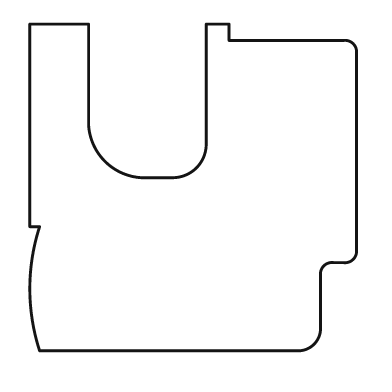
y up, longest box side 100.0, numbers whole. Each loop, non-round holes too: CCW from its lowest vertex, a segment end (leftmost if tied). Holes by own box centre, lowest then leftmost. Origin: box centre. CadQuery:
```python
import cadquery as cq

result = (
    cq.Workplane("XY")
    .moveTo(-47.0, -50.0)
    .lineTo(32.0, -50.0)
    .threePointArc((37.0, -48.0), (39.0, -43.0))
    .lineTo(39.0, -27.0)
    .threePointArc((40.0, -24.0), (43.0, -23.0))
    .lineTo(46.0, -23.0)
    .threePointArc((49.0, -22.0), (50.0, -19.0))
    .lineTo(50.0, 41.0)
    .threePointArc((49.0, 44.0), (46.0, 45.0))
    .lineTo(11.0, 45.0)
    .lineTo(11.0, 50.0)
    .lineTo(4.0, 50.0)
    .lineTo(4.0, 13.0)
    .threePointArc((1.0, 6.0), (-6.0, 3.0))
    .lineTo(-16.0, 3.0)
    .threePointArc((-27.0, 8.0), (-32.0, 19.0))
    .lineTo(-32.0, 50.0)
    .lineTo(-50.0, 50.0)
    .lineTo(-50.0, -12.0)
    .lineTo(-47.0, -12.0)
    .threePointArc((-50.0, -31.0), (-47.0, -50.0))
    .close()
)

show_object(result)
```